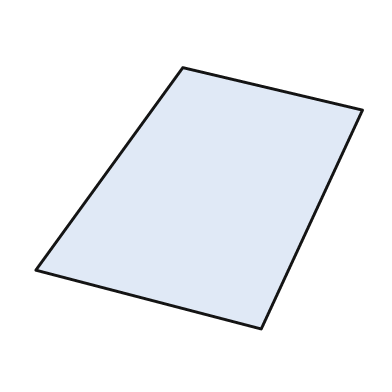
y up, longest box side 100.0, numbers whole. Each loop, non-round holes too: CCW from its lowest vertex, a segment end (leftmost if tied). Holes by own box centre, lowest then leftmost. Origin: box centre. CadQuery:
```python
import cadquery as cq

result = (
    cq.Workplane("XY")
    .moveTo(19.0, -40.0)
    .lineTo(50.0, 27.0)
    .lineTo(-5.0, 40.0)
    .lineTo(-50.0, -22.0)
    .close()
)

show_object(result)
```